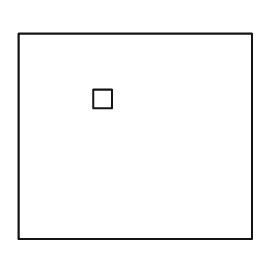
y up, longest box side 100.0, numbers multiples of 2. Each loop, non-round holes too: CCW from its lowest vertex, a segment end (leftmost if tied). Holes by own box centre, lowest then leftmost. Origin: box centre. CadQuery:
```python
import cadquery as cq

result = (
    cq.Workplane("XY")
    .moveTo(-50.0, -44.0)
    .lineTo(50.0, -44.0)
    .lineTo(50.0, 44.0)
    .lineTo(-50.0, 44.0)
    .close()
    .moveTo(-18.0, 12.0)
    .lineTo(-10.0, 12.0)
    .lineTo(-10.0, 20.0)
    .lineTo(-18.0, 20.0)
    .close()
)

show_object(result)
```